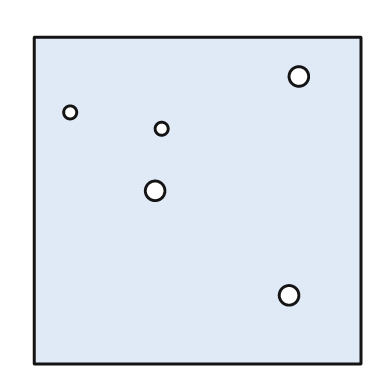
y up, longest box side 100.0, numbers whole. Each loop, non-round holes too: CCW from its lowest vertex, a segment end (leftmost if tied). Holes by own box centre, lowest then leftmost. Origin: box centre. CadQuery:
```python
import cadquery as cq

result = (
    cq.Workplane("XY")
    .moveTo(-50.0, -50.0)
    .lineTo(50.0, -50.0)
    .lineTo(50.0, 50.0)
    .lineTo(-50.0, 50.0)
    .close()
    .moveTo(28.0, -29.0)
    .circle(3.0)
    .moveTo(-13.0, 3.0)
    .circle(3.0)
    .moveTo(-11.0, 22.0)
    .circle(2.0)
    .moveTo(-39.0, 27.0)
    .circle(2.0)
    .moveTo(31.0, 38.0)
    .circle(3.0)
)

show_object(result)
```